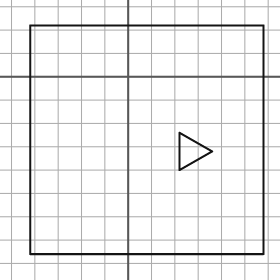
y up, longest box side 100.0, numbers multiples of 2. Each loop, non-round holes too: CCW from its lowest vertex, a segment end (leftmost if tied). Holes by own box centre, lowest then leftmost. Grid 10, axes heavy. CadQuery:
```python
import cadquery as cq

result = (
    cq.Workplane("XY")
    .moveTo(-42.0, -76.0)
    .lineTo(58.0, -76.0)
    .lineTo(58.0, 22.0)
    .lineTo(-42.0, 22.0)
    .close()
    .moveTo(22.0, -40.0)
    .lineTo(36.0, -32.0)
    .lineTo(22.0, -24.0)
    .close()
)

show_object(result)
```